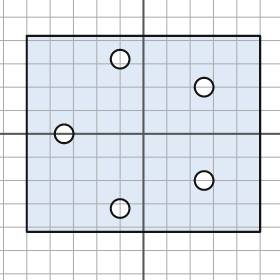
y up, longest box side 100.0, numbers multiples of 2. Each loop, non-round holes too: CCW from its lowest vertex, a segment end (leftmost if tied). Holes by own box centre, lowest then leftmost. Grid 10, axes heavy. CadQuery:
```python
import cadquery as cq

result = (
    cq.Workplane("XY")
    .moveTo(-50.0, -42.0)
    .lineTo(50.0, -42.0)
    .lineTo(50.0, 42.0)
    .lineTo(-50.0, 42.0)
    .close()
    .moveTo(-10.0, -32.0)
    .circle(4.0)
    .moveTo(26.0, -20.0)
    .circle(4.0)
    .moveTo(-34.0, 0.0)
    .circle(4.0)
    .moveTo(26.0, 20.0)
    .circle(4.0)
    .moveTo(-10.0, 32.0)
    .circle(4.0)
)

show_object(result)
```